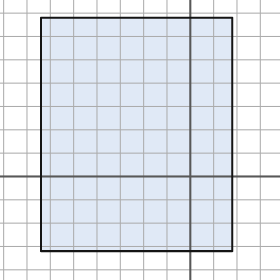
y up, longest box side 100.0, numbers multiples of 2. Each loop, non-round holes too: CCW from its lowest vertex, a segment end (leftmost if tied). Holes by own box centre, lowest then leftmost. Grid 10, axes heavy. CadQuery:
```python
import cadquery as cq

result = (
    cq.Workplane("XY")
    .moveTo(-64.0, -32.0)
    .lineTo(18.0, -32.0)
    .lineTo(18.0, 68.0)
    .lineTo(-64.0, 68.0)
    .close()
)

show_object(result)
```